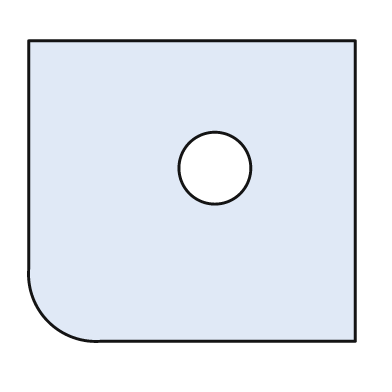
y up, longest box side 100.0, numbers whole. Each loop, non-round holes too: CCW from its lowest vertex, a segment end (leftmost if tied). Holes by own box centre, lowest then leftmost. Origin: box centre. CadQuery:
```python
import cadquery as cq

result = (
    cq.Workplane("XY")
    .moveTo(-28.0, -46.0)
    .lineTo(50.0, -46.0)
    .lineTo(50.0, 46.0)
    .lineTo(-50.0, 46.0)
    .lineTo(-50.0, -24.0)
    .threePointArc((-44.0, -40.0), (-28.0, -46.0))
    .close()
    .moveTo(7.0, 7.0)
    .circle(11.0)
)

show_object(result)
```